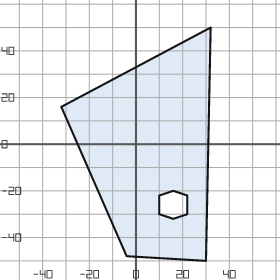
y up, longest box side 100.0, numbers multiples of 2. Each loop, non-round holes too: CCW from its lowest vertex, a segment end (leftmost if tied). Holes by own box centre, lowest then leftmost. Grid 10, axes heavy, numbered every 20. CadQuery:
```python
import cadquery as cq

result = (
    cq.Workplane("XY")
    .moveTo(30.0, -50.0)
    .lineTo(32.0, 50.0)
    .lineTo(-32.0, 16.0)
    .lineTo(-4.0, -48.0)
    .close()
    .moveTo(16.0, -32.0)
    .lineTo(22.0, -30.0)
    .lineTo(22.0, -22.0)
    .lineTo(16.0, -20.0)
    .lineTo(10.0, -22.0)
    .lineTo(10.0, -30.0)
    .close()
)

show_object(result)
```